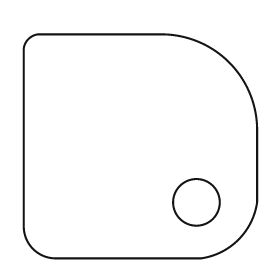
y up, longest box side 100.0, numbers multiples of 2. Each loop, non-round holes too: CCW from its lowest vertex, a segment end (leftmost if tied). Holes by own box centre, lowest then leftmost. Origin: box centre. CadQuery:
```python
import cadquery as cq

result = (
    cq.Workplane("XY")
    .moveTo(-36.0, -48.0)
    .lineTo(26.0, -48.0)
    .threePointArc((42.0, -40.0), (50.0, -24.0))
    .lineTo(50.0, 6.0)
    .threePointArc((38.0, 36.0), (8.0, 48.0))
    .lineTo(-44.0, 48.0)
    .threePointArc((-48.0, 46.0), (-50.0, 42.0))
    .lineTo(-50.0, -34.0)
    .threePointArc((-46.0, -44.0), (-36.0, -48.0))
    .close()
    .moveTo(24.0, -24.0)
    .circle(10.0)
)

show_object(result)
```